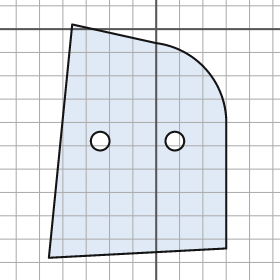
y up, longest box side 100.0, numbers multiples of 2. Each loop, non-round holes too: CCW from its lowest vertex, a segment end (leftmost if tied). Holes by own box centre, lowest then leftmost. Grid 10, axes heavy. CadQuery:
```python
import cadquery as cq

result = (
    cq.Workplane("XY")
    .moveTo(-46.0, -98.0)
    .lineTo(30.0, -94.0)
    .lineTo(30.0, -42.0)
    .threePointArc((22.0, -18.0), (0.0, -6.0))
    .lineTo(-36.0, 2.0)
    .close()
    .moveTo(-24.0, -48.0)
    .circle(4.0)
    .moveTo(8.0, -48.0)
    .circle(4.0)
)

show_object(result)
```